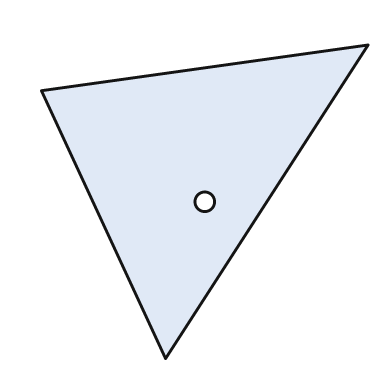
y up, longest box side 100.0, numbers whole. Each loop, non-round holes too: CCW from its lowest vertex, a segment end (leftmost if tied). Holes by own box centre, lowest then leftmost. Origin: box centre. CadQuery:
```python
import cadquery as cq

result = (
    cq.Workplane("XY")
    .moveTo(-12.0, -48.0)
    .lineTo(50.0, 48.0)
    .lineTo(-50.0, 34.0)
    .close()
    .moveTo(0.0, 0.0)
    .circle(3.0)
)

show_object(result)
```